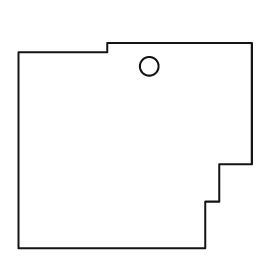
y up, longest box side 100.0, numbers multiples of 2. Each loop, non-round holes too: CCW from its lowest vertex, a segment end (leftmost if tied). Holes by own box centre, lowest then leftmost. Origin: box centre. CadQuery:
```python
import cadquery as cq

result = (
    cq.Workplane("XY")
    .moveTo(-50.0, -44.0)
    .lineTo(30.0, -44.0)
    .lineTo(30.0, -24.0)
    .lineTo(36.0, -24.0)
    .lineTo(36.0, -8.0)
    .lineTo(50.0, -8.0)
    .lineTo(50.0, 44.0)
    .lineTo(-12.0, 44.0)
    .lineTo(-12.0, 40.0)
    .lineTo(-50.0, 40.0)
    .close()
    .moveTo(6.0, 34.0)
    .circle(4.0)
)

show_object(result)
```